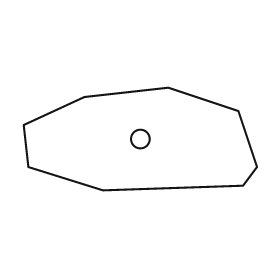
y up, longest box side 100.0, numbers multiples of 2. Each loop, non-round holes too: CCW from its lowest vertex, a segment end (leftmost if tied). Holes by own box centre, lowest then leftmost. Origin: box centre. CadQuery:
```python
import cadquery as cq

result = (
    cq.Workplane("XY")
    .moveTo(-16.0, -22.0)
    .lineTo(44.0, -20.0)
    .lineTo(50.0, -12.0)
    .lineTo(42.0, 12.0)
    .lineTo(12.0, 22.0)
    .lineTo(-24.0, 18.0)
    .lineTo(-50.0, 6.0)
    .lineTo(-48.0, -12.0)
    .close()
    .moveTo(0.0, 0.0)
    .circle(4.0)
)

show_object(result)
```